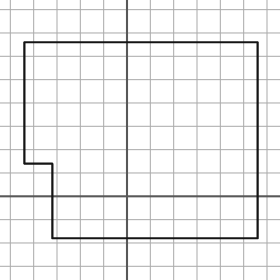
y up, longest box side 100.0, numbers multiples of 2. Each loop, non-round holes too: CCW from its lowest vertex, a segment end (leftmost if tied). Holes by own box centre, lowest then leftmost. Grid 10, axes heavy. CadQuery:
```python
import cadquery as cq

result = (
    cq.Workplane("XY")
    .moveTo(-32.0, -18.0)
    .lineTo(56.0, -18.0)
    .lineTo(56.0, 66.0)
    .lineTo(-44.0, 66.0)
    .lineTo(-44.0, 14.0)
    .lineTo(-32.0, 14.0)
    .close()
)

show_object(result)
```